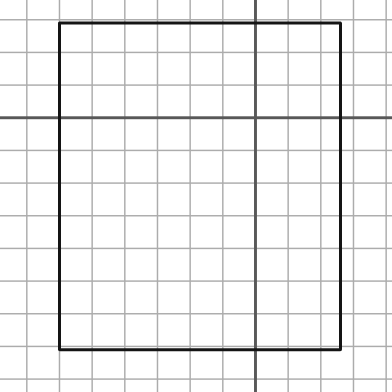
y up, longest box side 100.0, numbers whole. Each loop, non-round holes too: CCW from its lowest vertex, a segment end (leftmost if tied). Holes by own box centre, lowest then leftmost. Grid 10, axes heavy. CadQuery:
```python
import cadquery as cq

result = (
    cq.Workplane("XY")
    .moveTo(-60.0, -71.0)
    .lineTo(26.0, -71.0)
    .lineTo(26.0, 29.0)
    .lineTo(-60.0, 29.0)
    .close()
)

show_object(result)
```